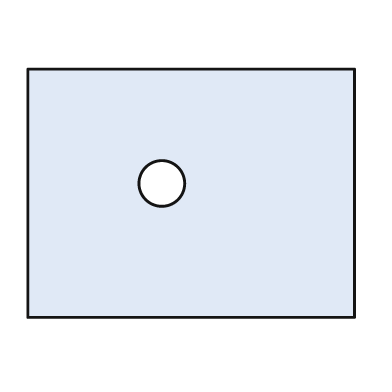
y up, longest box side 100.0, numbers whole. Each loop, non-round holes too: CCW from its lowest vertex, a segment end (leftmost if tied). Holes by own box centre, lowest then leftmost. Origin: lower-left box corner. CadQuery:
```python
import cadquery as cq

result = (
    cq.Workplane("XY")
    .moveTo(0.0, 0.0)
    .lineTo(100.0, 0.0)
    .lineTo(100.0, 76.0)
    .lineTo(0.0, 76.0)
    .close()
    .moveTo(41.0, 41.0)
    .circle(7.0)
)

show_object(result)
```